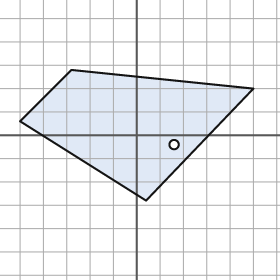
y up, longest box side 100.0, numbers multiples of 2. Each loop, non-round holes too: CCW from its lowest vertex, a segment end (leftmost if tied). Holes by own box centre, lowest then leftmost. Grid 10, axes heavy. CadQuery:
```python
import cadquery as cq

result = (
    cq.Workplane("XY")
    .moveTo(4.0, -28.0)
    .lineTo(50.0, 20.0)
    .lineTo(-28.0, 28.0)
    .lineTo(-50.0, 6.0)
    .close()
    .moveTo(16.0, -4.0)
    .circle(2.0)
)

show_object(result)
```